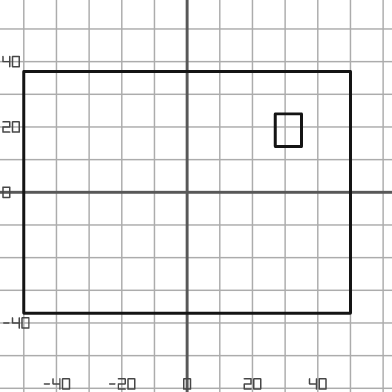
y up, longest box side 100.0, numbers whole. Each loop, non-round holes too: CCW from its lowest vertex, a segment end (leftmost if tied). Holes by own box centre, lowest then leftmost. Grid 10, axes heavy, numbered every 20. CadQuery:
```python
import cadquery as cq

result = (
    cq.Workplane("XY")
    .moveTo(-50.0, -37.0)
    .lineTo(50.0, -37.0)
    .lineTo(50.0, 37.0)
    .lineTo(-50.0, 37.0)
    .close()
    .moveTo(27.0, 14.0)
    .lineTo(35.0, 14.0)
    .lineTo(35.0, 24.0)
    .lineTo(27.0, 24.0)
    .close()
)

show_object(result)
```